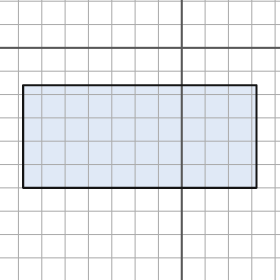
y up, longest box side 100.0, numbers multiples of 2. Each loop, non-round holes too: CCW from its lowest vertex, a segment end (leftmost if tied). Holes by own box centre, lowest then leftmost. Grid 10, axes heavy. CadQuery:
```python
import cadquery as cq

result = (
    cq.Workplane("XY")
    .moveTo(-68.0, -60.0)
    .lineTo(32.0, -60.0)
    .lineTo(32.0, -16.0)
    .lineTo(-68.0, -16.0)
    .close()
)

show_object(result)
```